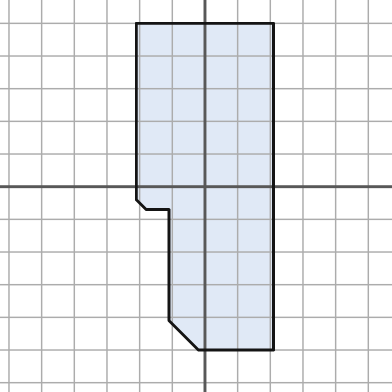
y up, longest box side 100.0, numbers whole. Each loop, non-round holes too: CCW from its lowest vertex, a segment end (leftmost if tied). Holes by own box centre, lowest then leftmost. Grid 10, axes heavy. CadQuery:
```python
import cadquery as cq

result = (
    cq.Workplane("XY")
    .moveTo(-2.0, -50.0)
    .lineTo(21.0, -50.0)
    .lineTo(21.0, 50.0)
    .lineTo(-21.0, 50.0)
    .lineTo(-21.0, -4.0)
    .lineTo(-18.0, -7.0)
    .lineTo(-11.0, -7.0)
    .lineTo(-11.0, -41.0)
    .close()
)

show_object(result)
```